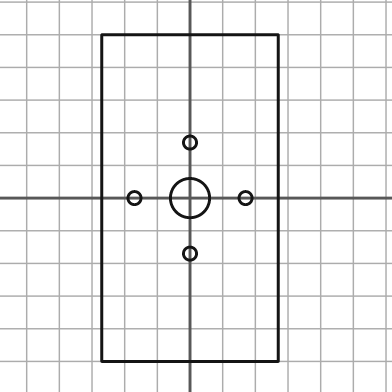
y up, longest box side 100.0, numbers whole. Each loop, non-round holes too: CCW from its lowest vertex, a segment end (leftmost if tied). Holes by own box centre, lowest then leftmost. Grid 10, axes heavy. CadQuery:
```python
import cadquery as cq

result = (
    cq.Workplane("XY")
    .moveTo(-27.0, -50.0)
    .lineTo(27.0, -50.0)
    .lineTo(27.0, 50.0)
    .lineTo(-27.0, 50.0)
    .close()
    .moveTo(0.0, -17.0)
    .circle(2.0)
    .moveTo(-17.0, 0.0)
    .circle(2.0)
    .moveTo(0.0, 0.0)
    .circle(6.0)
    .moveTo(17.0, 0.0)
    .circle(2.0)
    .moveTo(0.0, 17.0)
    .circle(2.0)
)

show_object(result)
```